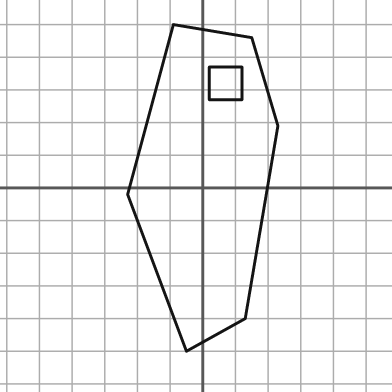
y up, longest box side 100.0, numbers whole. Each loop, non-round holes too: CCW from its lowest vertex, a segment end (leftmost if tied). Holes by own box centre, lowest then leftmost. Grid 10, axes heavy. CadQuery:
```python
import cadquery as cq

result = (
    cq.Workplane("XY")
    .moveTo(-5.0, -50.0)
    .lineTo(13.0, -40.0)
    .lineTo(23.0, 19.0)
    .lineTo(15.0, 46.0)
    .lineTo(-9.0, 50.0)
    .lineTo(-23.0, -2.0)
    .close()
    .moveTo(2.0, 27.0)
    .lineTo(12.0, 27.0)
    .lineTo(12.0, 37.0)
    .lineTo(2.0, 37.0)
    .close()
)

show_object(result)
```